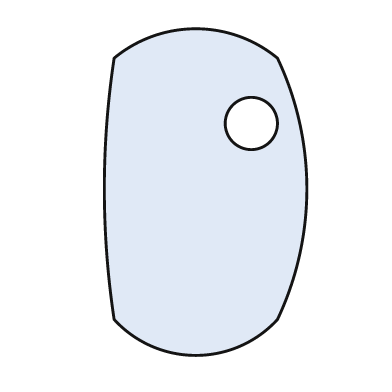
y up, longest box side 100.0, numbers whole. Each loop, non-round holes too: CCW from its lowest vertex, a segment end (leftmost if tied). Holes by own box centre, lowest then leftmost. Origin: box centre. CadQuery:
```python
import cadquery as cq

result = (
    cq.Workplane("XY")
    .moveTo(-28.0, -39.0)
    .threePointArc((-3.0, -50.0), (22.0, -39.0))
    .threePointArc((31.0, 1.0), (22.0, 41.0))
    .threePointArc((-3.0, 50.0), (-28.0, 41.0))
    .threePointArc((-31.0, 1.0), (-28.0, -39.0))
    .close()
    .moveTo(14.0, 21.0)
    .circle(8.0)
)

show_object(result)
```